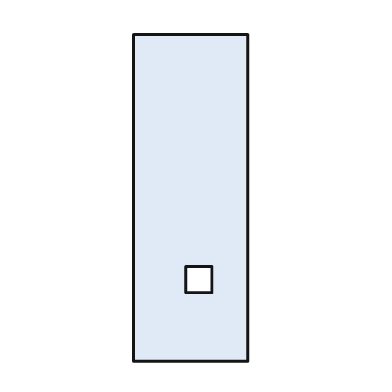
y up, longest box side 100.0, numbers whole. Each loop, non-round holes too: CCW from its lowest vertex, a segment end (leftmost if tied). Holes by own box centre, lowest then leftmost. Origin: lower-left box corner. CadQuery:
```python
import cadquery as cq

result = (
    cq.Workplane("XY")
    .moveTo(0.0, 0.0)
    .lineTo(35.0, 0.0)
    .lineTo(35.0, 100.0)
    .lineTo(0.0, 100.0)
    .close()
    .moveTo(16.0, 21.0)
    .lineTo(24.0, 21.0)
    .lineTo(24.0, 29.0)
    .lineTo(16.0, 29.0)
    .close()
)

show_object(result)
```